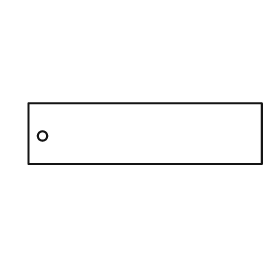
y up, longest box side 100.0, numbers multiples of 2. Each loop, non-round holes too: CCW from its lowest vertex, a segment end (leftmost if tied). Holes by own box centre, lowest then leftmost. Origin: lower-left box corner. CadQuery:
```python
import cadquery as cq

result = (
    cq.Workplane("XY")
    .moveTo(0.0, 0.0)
    .lineTo(100.0, 0.0)
    .lineTo(100.0, 26.0)
    .lineTo(0.0, 26.0)
    .close()
    .moveTo(6.0, 12.0)
    .circle(2.0)
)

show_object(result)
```